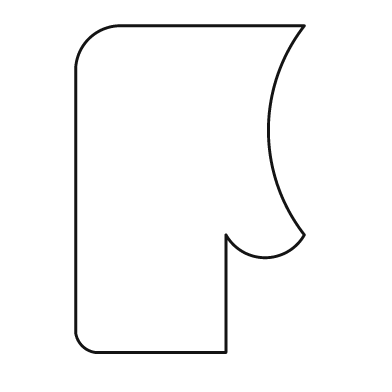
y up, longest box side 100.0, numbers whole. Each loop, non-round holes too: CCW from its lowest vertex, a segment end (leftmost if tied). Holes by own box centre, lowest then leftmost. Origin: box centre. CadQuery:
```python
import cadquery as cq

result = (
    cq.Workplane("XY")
    .moveTo(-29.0, -50.0)
    .lineTo(11.0, -50.0)
    .lineTo(11.0, -14.0)
    .threePointArc((23.0, -21.0), (35.0, -14.0))
    .threePointArc((24.0, 18.0), (35.0, 50.0))
    .lineTo(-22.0, 50.0)
    .threePointArc((-31.0, 46.0), (-35.0, 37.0))
    .lineTo(-35.0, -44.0)
    .threePointArc((-33.0, -48.0), (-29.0, -50.0))
    .close()
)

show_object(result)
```